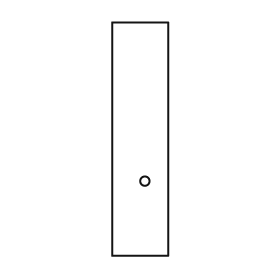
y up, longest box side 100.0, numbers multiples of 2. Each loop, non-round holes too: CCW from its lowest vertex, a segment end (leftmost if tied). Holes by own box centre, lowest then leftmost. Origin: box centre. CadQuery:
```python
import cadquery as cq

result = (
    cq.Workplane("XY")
    .moveTo(-12.0, -50.0)
    .lineTo(12.0, -50.0)
    .lineTo(12.0, 50.0)
    .lineTo(-12.0, 50.0)
    .close()
    .moveTo(2.0, -18.0)
    .circle(2.0)
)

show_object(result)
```